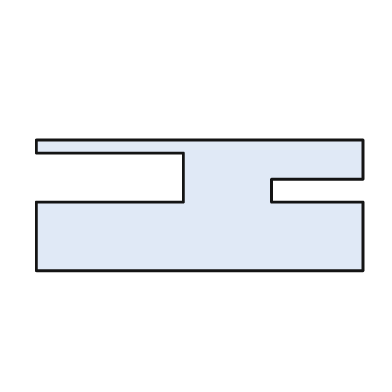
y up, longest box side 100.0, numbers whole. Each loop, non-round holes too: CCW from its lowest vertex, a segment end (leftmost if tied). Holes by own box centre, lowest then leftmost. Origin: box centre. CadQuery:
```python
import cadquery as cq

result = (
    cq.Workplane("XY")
    .moveTo(-50.0, -20.0)
    .lineTo(50.0, -20.0)
    .lineTo(50.0, 1.0)
    .lineTo(22.0, 1.0)
    .lineTo(22.0, 8.0)
    .lineTo(50.0, 8.0)
    .lineTo(50.0, 20.0)
    .lineTo(-50.0, 20.0)
    .lineTo(-50.0, 16.0)
    .lineTo(-5.0, 16.0)
    .lineTo(-5.0, 1.0)
    .lineTo(-50.0, 1.0)
    .close()
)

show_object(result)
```